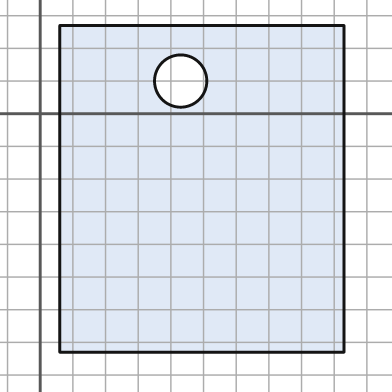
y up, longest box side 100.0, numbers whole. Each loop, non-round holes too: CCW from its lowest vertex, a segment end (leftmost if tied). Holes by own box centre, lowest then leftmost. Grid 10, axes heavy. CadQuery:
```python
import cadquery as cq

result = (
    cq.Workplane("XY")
    .moveTo(6.0, -73.0)
    .lineTo(93.0, -73.0)
    .lineTo(93.0, 27.0)
    .lineTo(6.0, 27.0)
    .close()
    .moveTo(43.0, 10.0)
    .circle(8.0)
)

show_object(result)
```